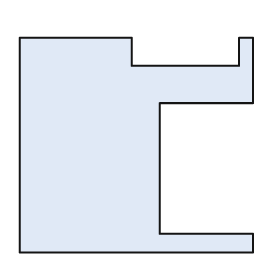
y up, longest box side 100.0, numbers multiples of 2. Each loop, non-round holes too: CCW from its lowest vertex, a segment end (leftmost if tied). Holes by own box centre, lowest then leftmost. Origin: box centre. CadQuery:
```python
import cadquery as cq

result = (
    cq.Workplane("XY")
    .moveTo(-50.0, -46.0)
    .lineTo(50.0, -46.0)
    .lineTo(50.0, -38.0)
    .lineTo(10.0, -38.0)
    .lineTo(10.0, 18.0)
    .lineTo(50.0, 18.0)
    .lineTo(50.0, 46.0)
    .lineTo(44.0, 46.0)
    .lineTo(44.0, 34.0)
    .lineTo(-2.0, 34.0)
    .lineTo(-2.0, 46.0)
    .lineTo(-50.0, 46.0)
    .close()
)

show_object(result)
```